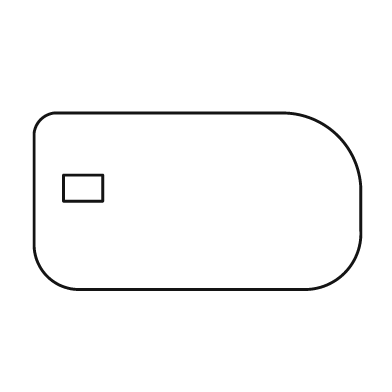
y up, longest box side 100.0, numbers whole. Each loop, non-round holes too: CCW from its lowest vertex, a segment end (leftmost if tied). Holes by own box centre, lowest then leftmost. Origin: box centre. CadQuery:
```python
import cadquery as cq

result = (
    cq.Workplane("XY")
    .moveTo(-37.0, -27.0)
    .lineTo(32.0, -27.0)
    .threePointArc((45.0, -22.0), (50.0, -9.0))
    .lineTo(50.0, 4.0)
    .threePointArc((43.0, 20.0), (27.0, 27.0))
    .lineTo(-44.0, 27.0)
    .threePointArc((-48.0, 25.0), (-50.0, 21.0))
    .lineTo(-50.0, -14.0)
    .threePointArc((-46.0, -23.0), (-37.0, -27.0))
    .close()
    .moveTo(-41.0, 0.0)
    .lineTo(-29.0, 0.0)
    .lineTo(-29.0, 8.0)
    .lineTo(-41.0, 8.0)
    .close()
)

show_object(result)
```